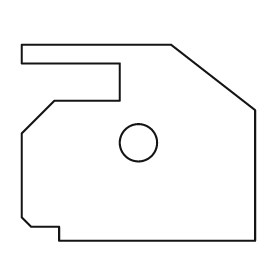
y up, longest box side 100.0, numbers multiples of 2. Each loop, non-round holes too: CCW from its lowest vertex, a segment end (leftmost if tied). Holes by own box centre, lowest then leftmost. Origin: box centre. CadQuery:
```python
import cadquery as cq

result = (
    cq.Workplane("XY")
    .moveTo(-34.0, -42.0)
    .lineTo(50.0, -42.0)
    .lineTo(50.0, 14.0)
    .lineTo(14.0, 42.0)
    .lineTo(-50.0, 42.0)
    .lineTo(-50.0, 34.0)
    .lineTo(-8.0, 34.0)
    .lineTo(-8.0, 18.0)
    .lineTo(-36.0, 18.0)
    .lineTo(-50.0, 4.0)
    .lineTo(-50.0, -32.0)
    .lineTo(-46.0, -36.0)
    .lineTo(-34.0, -36.0)
    .close()
    .moveTo(0.0, 0.0)
    .circle(8.0)
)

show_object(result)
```